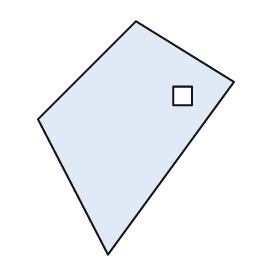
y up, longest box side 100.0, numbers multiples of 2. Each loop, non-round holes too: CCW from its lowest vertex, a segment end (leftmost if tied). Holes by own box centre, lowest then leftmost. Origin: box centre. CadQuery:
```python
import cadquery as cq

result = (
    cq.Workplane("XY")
    .moveTo(-12.0, -50.0)
    .lineTo(42.0, 24.0)
    .lineTo(0.0, 50.0)
    .lineTo(-42.0, 8.0)
    .close()
    .moveTo(16.0, 14.0)
    .lineTo(24.0, 14.0)
    .lineTo(24.0, 22.0)
    .lineTo(16.0, 22.0)
    .close()
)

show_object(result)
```